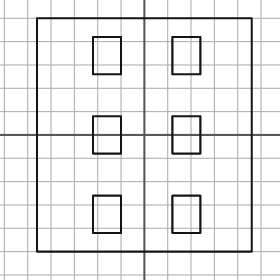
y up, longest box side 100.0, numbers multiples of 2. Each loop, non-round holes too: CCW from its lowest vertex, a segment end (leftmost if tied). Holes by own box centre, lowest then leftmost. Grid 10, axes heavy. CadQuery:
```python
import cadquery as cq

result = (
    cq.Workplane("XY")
    .moveTo(-46.0, -50.0)
    .lineTo(46.0, -50.0)
    .lineTo(46.0, 50.0)
    .lineTo(-46.0, 50.0)
    .close()
    .moveTo(-22.0, -42.0)
    .lineTo(-10.0, -42.0)
    .lineTo(-10.0, -26.0)
    .lineTo(-22.0, -26.0)
    .close()
    .moveTo(12.0, -42.0)
    .lineTo(24.0, -42.0)
    .lineTo(24.0, -26.0)
    .lineTo(12.0, -26.0)
    .close()
    .moveTo(-22.0, -8.0)
    .lineTo(-10.0, -8.0)
    .lineTo(-10.0, 8.0)
    .lineTo(-22.0, 8.0)
    .close()
    .moveTo(12.0, -8.0)
    .lineTo(24.0, -8.0)
    .lineTo(24.0, 8.0)
    .lineTo(12.0, 8.0)
    .close()
    .moveTo(-22.0, 26.0)
    .lineTo(-10.0, 26.0)
    .lineTo(-10.0, 42.0)
    .lineTo(-22.0, 42.0)
    .close()
    .moveTo(12.0, 26.0)
    .lineTo(24.0, 26.0)
    .lineTo(24.0, 42.0)
    .lineTo(12.0, 42.0)
    .close()
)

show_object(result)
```